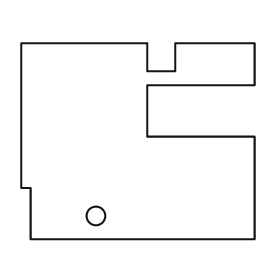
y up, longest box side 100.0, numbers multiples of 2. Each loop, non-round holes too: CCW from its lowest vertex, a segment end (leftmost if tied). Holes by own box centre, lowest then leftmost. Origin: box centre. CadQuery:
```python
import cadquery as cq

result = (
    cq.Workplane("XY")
    .moveTo(-46.0, -42.0)
    .lineTo(50.0, -42.0)
    .lineTo(50.0, 2.0)
    .lineTo(4.0, 2.0)
    .lineTo(4.0, 24.0)
    .lineTo(50.0, 24.0)
    .lineTo(50.0, 42.0)
    .lineTo(16.0, 42.0)
    .lineTo(16.0, 30.0)
    .lineTo(4.0, 30.0)
    .lineTo(4.0, 42.0)
    .lineTo(-50.0, 42.0)
    .lineTo(-50.0, -20.0)
    .lineTo(-46.0, -20.0)
    .close()
    .moveTo(-18.0, -32.0)
    .circle(4.0)
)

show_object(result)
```